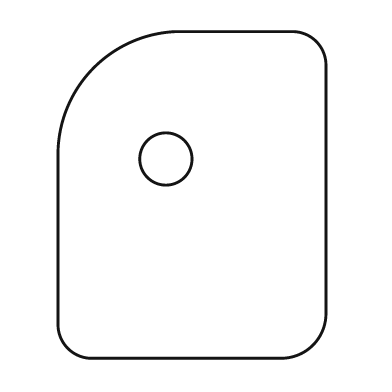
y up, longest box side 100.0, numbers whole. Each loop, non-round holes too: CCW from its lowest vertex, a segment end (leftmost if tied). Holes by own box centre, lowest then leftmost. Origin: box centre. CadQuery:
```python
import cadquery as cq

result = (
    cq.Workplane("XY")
    .moveTo(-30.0, -50.0)
    .lineTo(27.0, -50.0)
    .threePointArc((37.0, -46.0), (41.0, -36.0))
    .lineTo(41.0, 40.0)
    .threePointArc((38.0, 47.0), (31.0, 50.0))
    .lineTo(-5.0, 50.0)
    .threePointArc((-30.0, 39.0), (-41.0, 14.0))
    .lineTo(-41.0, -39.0)
    .threePointArc((-38.0, -47.0), (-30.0, -50.0))
    .close()
    .moveTo(-8.0, 11.0)
    .circle(8.0)
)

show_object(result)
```